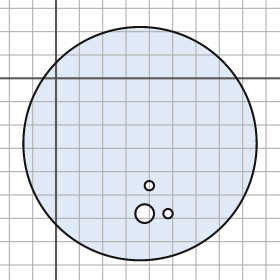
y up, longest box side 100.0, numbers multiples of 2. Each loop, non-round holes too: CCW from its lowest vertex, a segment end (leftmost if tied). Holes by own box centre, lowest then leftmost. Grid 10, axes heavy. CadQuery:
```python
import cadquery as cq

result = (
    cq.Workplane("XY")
    .moveTo(36.0, -28.0)
    .circle(50.0)
    .moveTo(38.0, -58.0)
    .circle(4.0)
    .moveTo(48.0, -58.0)
    .circle(2.0)
    .moveTo(40.0, -46.0)
    .circle(2.0)
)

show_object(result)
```